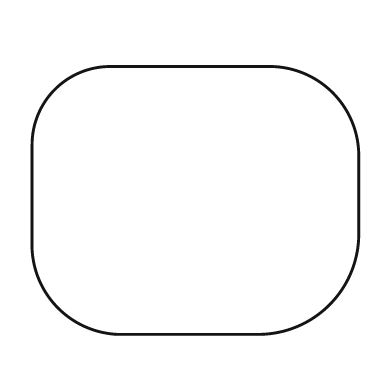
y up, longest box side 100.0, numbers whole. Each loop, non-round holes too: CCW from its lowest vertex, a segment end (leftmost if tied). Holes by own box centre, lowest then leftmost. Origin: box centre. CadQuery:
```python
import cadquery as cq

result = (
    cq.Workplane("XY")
    .moveTo(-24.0, -41.0)
    .lineTo(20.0, -41.0)
    .threePointArc((41.0, -32.0), (50.0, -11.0))
    .lineTo(50.0, 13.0)
    .threePointArc((42.0, 33.0), (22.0, 41.0))
    .lineTo(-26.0, 41.0)
    .threePointArc((-43.0, 34.0), (-50.0, 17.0))
    .lineTo(-50.0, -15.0)
    .threePointArc((-42.0, -33.0), (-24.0, -41.0))
    .close()
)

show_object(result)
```